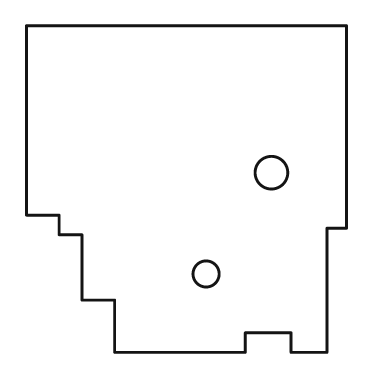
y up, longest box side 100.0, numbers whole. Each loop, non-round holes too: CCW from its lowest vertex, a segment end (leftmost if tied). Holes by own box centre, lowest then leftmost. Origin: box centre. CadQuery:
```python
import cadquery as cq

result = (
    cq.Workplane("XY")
    .moveTo(-22.0, -50.0)
    .lineTo(18.0, -50.0)
    .lineTo(18.0, -44.0)
    .lineTo(32.0, -44.0)
    .lineTo(32.0, -50.0)
    .lineTo(43.0, -50.0)
    .lineTo(43.0, -12.0)
    .lineTo(49.0, -12.0)
    .lineTo(49.0, 50.0)
    .lineTo(-49.0, 50.0)
    .lineTo(-49.0, -8.0)
    .lineTo(-39.0, -8.0)
    .lineTo(-39.0, -14.0)
    .lineTo(-32.0, -14.0)
    .lineTo(-32.0, -34.0)
    .lineTo(-22.0, -34.0)
    .close()
    .moveTo(6.0, -26.0)
    .circle(4.0)
    .moveTo(26.0, 5.0)
    .circle(5.0)
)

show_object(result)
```